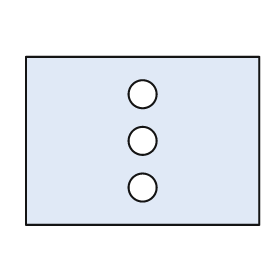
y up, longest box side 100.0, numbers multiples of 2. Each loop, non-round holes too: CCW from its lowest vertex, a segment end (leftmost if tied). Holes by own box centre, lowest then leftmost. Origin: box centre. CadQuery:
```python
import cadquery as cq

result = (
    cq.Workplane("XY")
    .moveTo(-50.0, -36.0)
    .lineTo(50.0, -36.0)
    .lineTo(50.0, 36.0)
    .lineTo(-50.0, 36.0)
    .close()
    .moveTo(0.0, -20.0)
    .circle(6.0)
    .moveTo(0.0, 0.0)
    .circle(6.0)
    .moveTo(0.0, 20.0)
    .circle(6.0)
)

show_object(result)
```